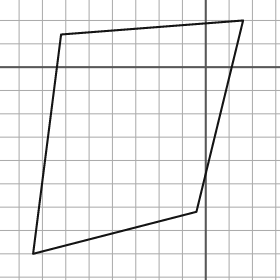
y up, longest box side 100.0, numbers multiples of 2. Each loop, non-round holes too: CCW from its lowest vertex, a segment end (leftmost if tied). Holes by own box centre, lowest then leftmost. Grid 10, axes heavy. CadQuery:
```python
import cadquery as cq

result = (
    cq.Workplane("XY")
    .moveTo(-74.0, -80.0)
    .lineTo(-4.0, -62.0)
    .lineTo(16.0, 20.0)
    .lineTo(-62.0, 14.0)
    .close()
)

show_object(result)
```